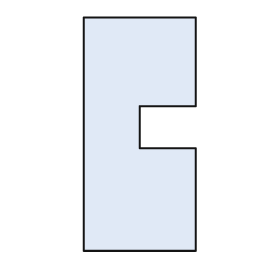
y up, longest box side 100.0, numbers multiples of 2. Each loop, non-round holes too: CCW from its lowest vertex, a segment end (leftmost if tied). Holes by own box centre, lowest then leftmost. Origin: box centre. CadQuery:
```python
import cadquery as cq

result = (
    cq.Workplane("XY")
    .moveTo(-24.0, -50.0)
    .lineTo(24.0, -50.0)
    .lineTo(24.0, -6.0)
    .lineTo(0.0, -6.0)
    .lineTo(0.0, 12.0)
    .lineTo(24.0, 12.0)
    .lineTo(24.0, 50.0)
    .lineTo(-24.0, 50.0)
    .close()
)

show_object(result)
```